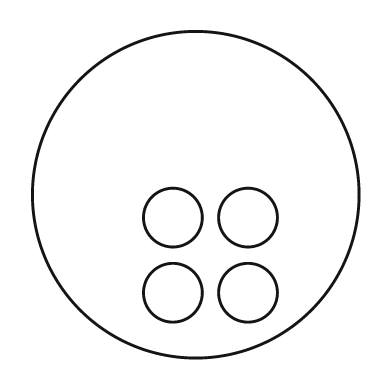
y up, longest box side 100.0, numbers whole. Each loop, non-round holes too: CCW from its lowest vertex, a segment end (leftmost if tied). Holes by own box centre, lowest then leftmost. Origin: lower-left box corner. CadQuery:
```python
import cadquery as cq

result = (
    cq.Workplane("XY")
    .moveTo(50.0, 50.0)
    .circle(50.0)
    .moveTo(43.0, 20.0)
    .circle(9.0)
    .moveTo(66.0, 20.0)
    .circle(9.0)
    .moveTo(43.0, 43.0)
    .circle(9.0)
    .moveTo(66.0, 43.0)
    .circle(9.0)
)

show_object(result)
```